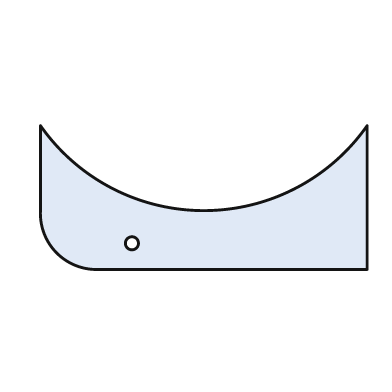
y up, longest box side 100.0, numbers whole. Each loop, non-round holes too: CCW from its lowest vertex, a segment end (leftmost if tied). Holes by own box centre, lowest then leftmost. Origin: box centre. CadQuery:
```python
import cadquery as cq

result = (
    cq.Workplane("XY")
    .moveTo(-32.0, -22.0)
    .lineTo(50.0, -22.0)
    .lineTo(50.0, 22.0)
    .threePointArc((0.0, -4.0), (-50.0, 22.0))
    .lineTo(-50.0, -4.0)
    .threePointArc((-45.0, -17.0), (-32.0, -22.0))
    .close()
    .moveTo(-22.0, -14.0)
    .circle(2.0)
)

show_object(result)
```